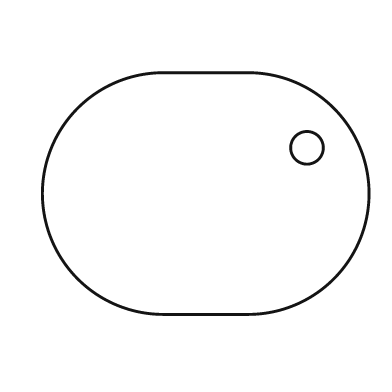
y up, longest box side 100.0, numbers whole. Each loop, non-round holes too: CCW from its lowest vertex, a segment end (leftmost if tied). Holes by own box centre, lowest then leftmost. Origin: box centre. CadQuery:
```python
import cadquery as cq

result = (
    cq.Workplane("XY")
    .moveTo(-13.0, -37.0)
    .lineTo(13.0, -37.0)
    .threePointArc((50.0, 0.0), (13.0, 37.0))
    .lineTo(-13.0, 37.0)
    .threePointArc((-50.0, 0.0), (-13.0, -37.0))
    .close()
    .moveTo(31.0, 14.0)
    .circle(5.0)
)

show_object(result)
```